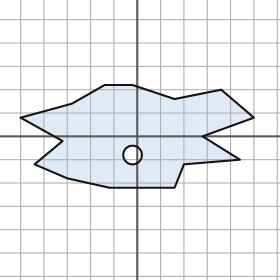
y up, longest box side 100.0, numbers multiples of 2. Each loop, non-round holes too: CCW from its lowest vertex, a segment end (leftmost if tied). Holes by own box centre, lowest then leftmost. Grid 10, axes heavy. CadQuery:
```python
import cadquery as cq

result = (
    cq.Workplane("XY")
    .moveTo(-12.0, -22.0)
    .lineTo(16.0, -22.0)
    .lineTo(20.0, -12.0)
    .lineTo(44.0, -10.0)
    .lineTo(28.0, 0.0)
    .lineTo(50.0, 8.0)
    .lineTo(36.0, 20.0)
    .lineTo(16.0, 16.0)
    .lineTo(-2.0, 22.0)
    .lineTo(-14.0, 22.0)
    .lineTo(-28.0, 14.0)
    .lineTo(-50.0, 8.0)
    .lineTo(-32.0, -2.0)
    .lineTo(-44.0, -12.0)
    .lineTo(-30.0, -18.0)
    .close()
    .moveTo(-2.0, -8.0)
    .circle(4.0)
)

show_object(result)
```